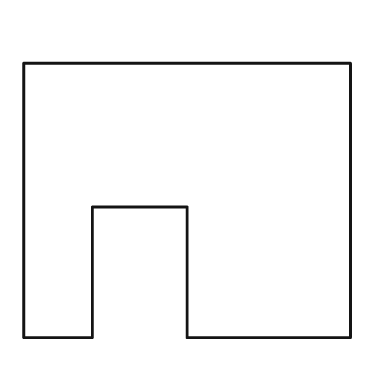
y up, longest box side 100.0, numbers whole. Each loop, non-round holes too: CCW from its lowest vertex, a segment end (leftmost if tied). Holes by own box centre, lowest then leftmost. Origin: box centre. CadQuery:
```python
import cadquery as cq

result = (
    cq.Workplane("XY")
    .moveTo(-50.0, -42.0)
    .lineTo(-29.0, -42.0)
    .lineTo(-29.0, -2.0)
    .lineTo(0.0, -2.0)
    .lineTo(0.0, -42.0)
    .lineTo(50.0, -42.0)
    .lineTo(50.0, 42.0)
    .lineTo(-50.0, 42.0)
    .close()
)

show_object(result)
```